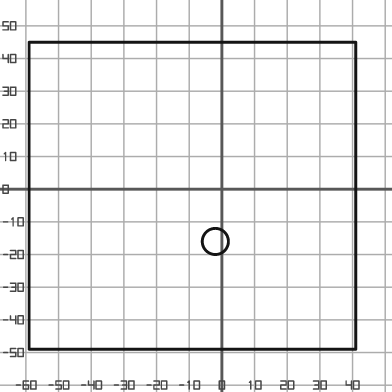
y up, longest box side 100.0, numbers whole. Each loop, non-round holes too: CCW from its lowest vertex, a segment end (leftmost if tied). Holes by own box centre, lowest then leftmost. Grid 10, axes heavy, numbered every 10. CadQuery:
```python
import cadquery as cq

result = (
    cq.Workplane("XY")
    .moveTo(-59.0, -49.0)
    .lineTo(41.0, -49.0)
    .lineTo(41.0, 45.0)
    .lineTo(-59.0, 45.0)
    .close()
    .moveTo(-2.0, -16.0)
    .circle(4.0)
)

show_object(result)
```